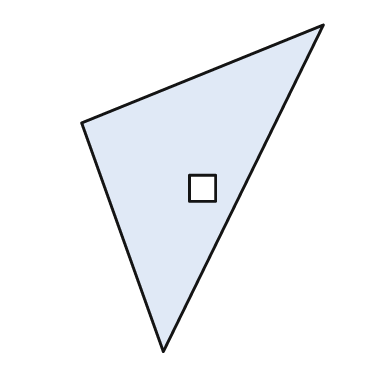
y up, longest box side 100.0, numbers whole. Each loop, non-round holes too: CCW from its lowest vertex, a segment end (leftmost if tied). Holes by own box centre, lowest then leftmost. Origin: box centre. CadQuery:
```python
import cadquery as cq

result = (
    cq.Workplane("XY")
    .moveTo(-12.0, -50.0)
    .lineTo(37.0, 50.0)
    .lineTo(-37.0, 20.0)
    .close()
    .moveTo(-4.0, -4.0)
    .lineTo(4.0, -4.0)
    .lineTo(4.0, 4.0)
    .lineTo(-4.0, 4.0)
    .close()
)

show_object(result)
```